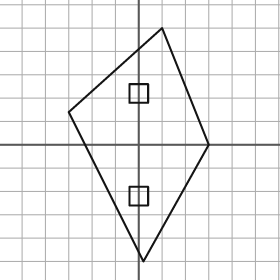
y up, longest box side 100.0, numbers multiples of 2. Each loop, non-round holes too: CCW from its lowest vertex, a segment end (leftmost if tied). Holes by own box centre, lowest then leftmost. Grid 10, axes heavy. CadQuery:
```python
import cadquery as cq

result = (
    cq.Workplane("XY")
    .moveTo(2.0, -50.0)
    .lineTo(30.0, 0.0)
    .lineTo(10.0, 50.0)
    .lineTo(-30.0, 14.0)
    .close()
    .moveTo(-4.0, -26.0)
    .lineTo(4.0, -26.0)
    .lineTo(4.0, -18.0)
    .lineTo(-4.0, -18.0)
    .close()
    .moveTo(-4.0, 18.0)
    .lineTo(4.0, 18.0)
    .lineTo(4.0, 26.0)
    .lineTo(-4.0, 26.0)
    .close()
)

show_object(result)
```